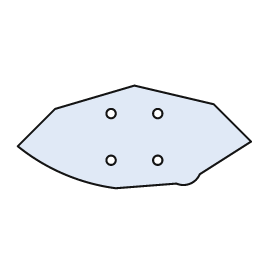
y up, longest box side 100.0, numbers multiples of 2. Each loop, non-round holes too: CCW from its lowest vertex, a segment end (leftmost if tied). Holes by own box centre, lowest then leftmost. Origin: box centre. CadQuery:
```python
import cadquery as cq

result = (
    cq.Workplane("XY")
    .moveTo(-8.0, -22.0)
    .lineTo(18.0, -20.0)
    .threePointArc((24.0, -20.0), (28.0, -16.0))
    .lineTo(50.0, -2.0)
    .lineTo(34.0, 14.0)
    .lineTo(0.0, 22.0)
    .lineTo(-34.0, 12.0)
    .lineTo(-50.0, -4.0)
    .threePointArc((-30.0, -16.0), (-8.0, -22.0))
    .close()
    .moveTo(-10.0, -10.0)
    .circle(2.0)
    .moveTo(10.0, -10.0)
    .circle(2.0)
    .moveTo(-10.0, 10.0)
    .circle(2.0)
    .moveTo(10.0, 10.0)
    .circle(2.0)
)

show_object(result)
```